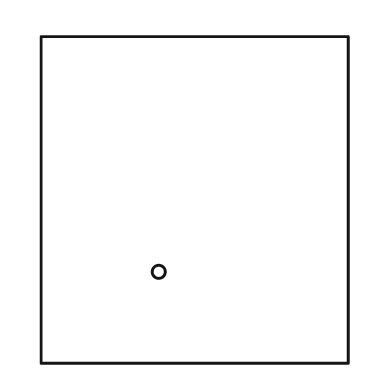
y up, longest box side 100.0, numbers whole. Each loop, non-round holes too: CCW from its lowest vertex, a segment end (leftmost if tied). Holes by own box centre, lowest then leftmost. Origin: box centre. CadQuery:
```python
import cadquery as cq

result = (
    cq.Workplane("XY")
    .moveTo(-47.0, -50.0)
    .lineTo(47.0, -50.0)
    .lineTo(47.0, 50.0)
    .lineTo(-47.0, 50.0)
    .close()
    .moveTo(-11.0, -22.0)
    .circle(2.0)
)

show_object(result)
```